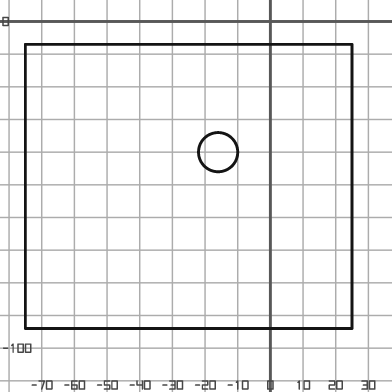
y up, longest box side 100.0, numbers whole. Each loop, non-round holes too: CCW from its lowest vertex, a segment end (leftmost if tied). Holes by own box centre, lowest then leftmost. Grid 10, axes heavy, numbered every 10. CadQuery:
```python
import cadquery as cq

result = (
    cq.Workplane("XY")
    .moveTo(-75.0, -94.0)
    .lineTo(25.0, -94.0)
    .lineTo(25.0, -7.0)
    .lineTo(-75.0, -7.0)
    .close()
    .moveTo(-16.0, -40.0)
    .circle(6.0)
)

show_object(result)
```